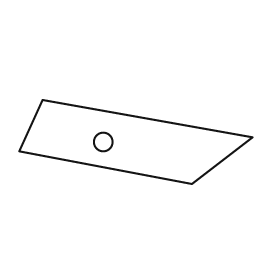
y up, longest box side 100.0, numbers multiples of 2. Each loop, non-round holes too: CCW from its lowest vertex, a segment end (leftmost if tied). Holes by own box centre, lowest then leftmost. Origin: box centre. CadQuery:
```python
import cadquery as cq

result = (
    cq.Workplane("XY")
    .moveTo(24.0, -18.0)
    .lineTo(50.0, 2.0)
    .lineTo(-40.0, 18.0)
    .lineTo(-50.0, -4.0)
    .close()
    .moveTo(-14.0, 0.0)
    .circle(4.0)
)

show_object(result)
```